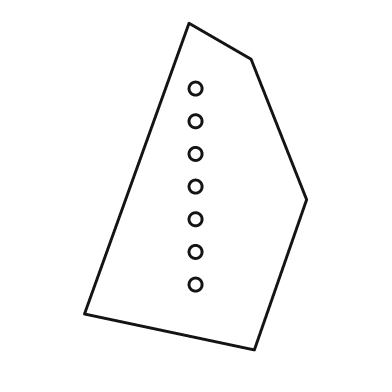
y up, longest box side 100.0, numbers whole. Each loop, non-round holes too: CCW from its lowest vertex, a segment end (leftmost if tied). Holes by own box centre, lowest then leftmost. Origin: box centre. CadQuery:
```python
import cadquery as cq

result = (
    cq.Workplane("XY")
    .moveTo(18.0, -50.0)
    .lineTo(34.0, -4.0)
    .lineTo(17.0, 39.0)
    .lineTo(-2.0, 50.0)
    .lineTo(-34.0, -39.0)
    .close()
    .moveTo(0.0, -30.0)
    .circle(2.0)
    .moveTo(0.0, -20.0)
    .circle(2.0)
    .moveTo(0.0, -10.0)
    .circle(2.0)
    .moveTo(0.0, 0.0)
    .circle(2.0)
    .moveTo(0.0, 10.0)
    .circle(2.0)
    .moveTo(0.0, 20.0)
    .circle(2.0)
    .moveTo(0.0, 30.0)
    .circle(2.0)
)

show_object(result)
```